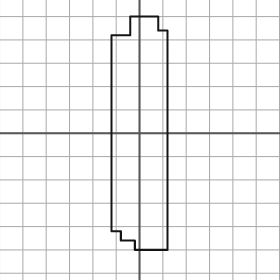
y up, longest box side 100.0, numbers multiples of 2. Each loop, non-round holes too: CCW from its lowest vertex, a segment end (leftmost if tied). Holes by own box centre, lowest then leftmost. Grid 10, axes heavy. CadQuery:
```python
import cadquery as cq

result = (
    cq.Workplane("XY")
    .moveTo(-2.0, -50.0)
    .lineTo(12.0, -50.0)
    .lineTo(12.0, 44.0)
    .lineTo(8.0, 44.0)
    .lineTo(8.0, 50.0)
    .lineTo(-4.0, 50.0)
    .lineTo(-4.0, 42.0)
    .lineTo(-12.0, 42.0)
    .lineTo(-12.0, -42.0)
    .lineTo(-8.0, -42.0)
    .lineTo(-8.0, -46.0)
    .lineTo(-2.0, -46.0)
    .close()
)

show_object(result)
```